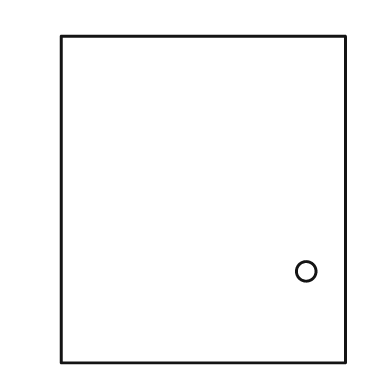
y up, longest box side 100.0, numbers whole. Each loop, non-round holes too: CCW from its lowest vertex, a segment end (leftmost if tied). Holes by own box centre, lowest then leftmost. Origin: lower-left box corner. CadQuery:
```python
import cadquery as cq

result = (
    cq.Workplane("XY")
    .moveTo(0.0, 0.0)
    .lineTo(87.0, 0.0)
    .lineTo(87.0, 100.0)
    .lineTo(0.0, 100.0)
    .close()
    .moveTo(75.0, 28.0)
    .circle(3.0)
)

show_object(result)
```